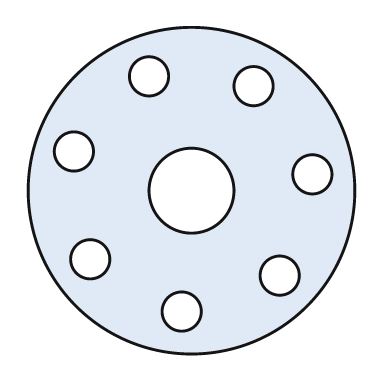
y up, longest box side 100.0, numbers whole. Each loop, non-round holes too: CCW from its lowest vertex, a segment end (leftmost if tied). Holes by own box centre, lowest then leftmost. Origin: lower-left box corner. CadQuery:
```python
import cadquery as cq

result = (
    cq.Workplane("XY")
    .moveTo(50.0, 50.0)
    .circle(50.0)
    .moveTo(47.0, 13.0)
    .circle(6.0)
    .moveTo(77.0, 24.0)
    .circle(6.0)
    .moveTo(19.0, 29.0)
    .circle(6.0)
    .moveTo(50.0, 50.0)
    .circle(13.0)
    .moveTo(87.0, 55.0)
    .circle(6.0)
    .moveTo(14.0, 62.0)
    .circle(6.0)
    .moveTo(69.0, 82.0)
    .circle(6.0)
    .moveTo(37.0, 85.0)
    .circle(6.0)
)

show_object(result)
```